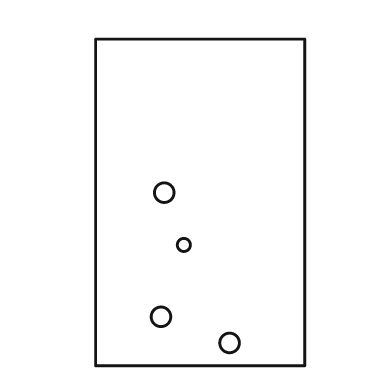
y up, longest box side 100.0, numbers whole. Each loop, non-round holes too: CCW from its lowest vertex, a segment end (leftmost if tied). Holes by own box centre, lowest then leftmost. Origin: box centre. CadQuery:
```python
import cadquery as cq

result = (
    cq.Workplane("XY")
    .moveTo(-32.0, -50.0)
    .lineTo(32.0, -50.0)
    .lineTo(32.0, 50.0)
    .lineTo(-32.0, 50.0)
    .close()
    .moveTo(9.0, -43.0)
    .circle(3.0)
    .moveTo(-12.0, -35.0)
    .circle(3.0)
    .moveTo(-5.0, -13.0)
    .circle(2.0)
    .moveTo(-11.0, 3.0)
    .circle(3.0)
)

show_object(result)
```